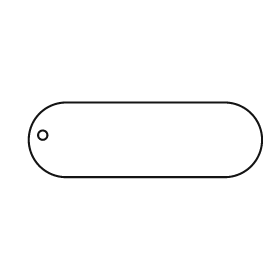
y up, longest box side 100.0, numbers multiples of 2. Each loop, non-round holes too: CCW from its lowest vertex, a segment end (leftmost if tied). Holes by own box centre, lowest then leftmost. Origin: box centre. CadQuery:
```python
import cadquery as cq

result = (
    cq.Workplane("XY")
    .moveTo(-34.0, -16.0)
    .lineTo(34.0, -16.0)
    .threePointArc((50.0, 0.0), (34.0, 16.0))
    .lineTo(-34.0, 16.0)
    .threePointArc((-50.0, 0.0), (-34.0, -16.0))
    .close()
    .moveTo(-44.0, 2.0)
    .circle(2.0)
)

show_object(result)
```